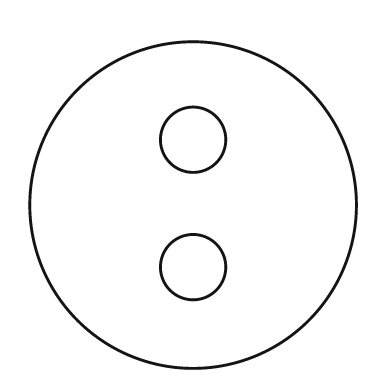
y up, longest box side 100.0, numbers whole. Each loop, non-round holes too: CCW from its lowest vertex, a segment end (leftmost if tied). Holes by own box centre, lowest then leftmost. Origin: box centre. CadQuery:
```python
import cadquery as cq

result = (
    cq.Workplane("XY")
    .moveTo(0.0, 0.0)
    .circle(50.0)
    .moveTo(0.0, -19.0)
    .circle(10.0)
    .moveTo(0.0, 20.0)
    .circle(10.0)
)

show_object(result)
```